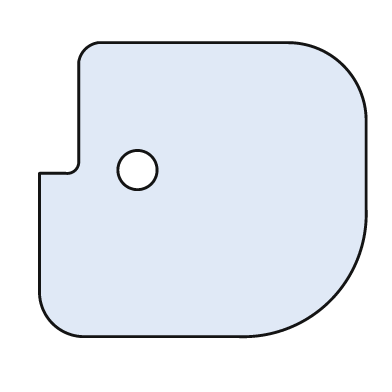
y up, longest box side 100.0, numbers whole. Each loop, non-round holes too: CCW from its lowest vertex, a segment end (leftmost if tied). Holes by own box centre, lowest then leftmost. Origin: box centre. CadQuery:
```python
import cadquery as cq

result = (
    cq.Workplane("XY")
    .moveTo(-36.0, -45.0)
    .lineTo(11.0, -45.0)
    .threePointArc((39.0, -34.0), (50.0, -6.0))
    .lineTo(50.0, 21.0)
    .threePointArc((43.0, 38.0), (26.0, 45.0))
    .lineTo(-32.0, 45.0)
    .threePointArc((-36.0, 43.0), (-38.0, 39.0))
    .lineTo(-38.0, 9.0)
    .threePointArc((-39.0, 6.0), (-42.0, 5.0))
    .lineTo(-50.0, 5.0)
    .lineTo(-50.0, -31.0)
    .threePointArc((-46.0, -41.0), (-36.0, -45.0))
    .close()
    .moveTo(-20.0, 6.0)
    .circle(6.0)
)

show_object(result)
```